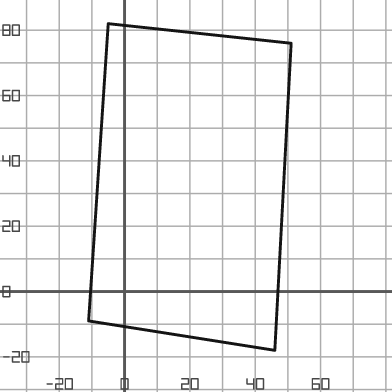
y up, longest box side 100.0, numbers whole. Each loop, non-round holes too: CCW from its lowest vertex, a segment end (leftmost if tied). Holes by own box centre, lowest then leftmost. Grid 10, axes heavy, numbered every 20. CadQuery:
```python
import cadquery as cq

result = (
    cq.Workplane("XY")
    .moveTo(46.0, -18.0)
    .lineTo(51.0, 76.0)
    .lineTo(-5.0, 82.0)
    .lineTo(-11.0, -9.0)
    .close()
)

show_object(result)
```